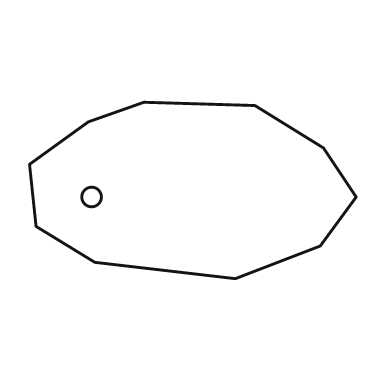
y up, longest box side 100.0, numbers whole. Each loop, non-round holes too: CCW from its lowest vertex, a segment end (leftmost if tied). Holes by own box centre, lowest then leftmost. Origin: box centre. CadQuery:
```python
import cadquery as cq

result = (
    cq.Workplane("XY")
    .moveTo(13.0, -27.0)
    .lineTo(39.0, -17.0)
    .lineTo(50.0, -2.0)
    .lineTo(40.0, 13.0)
    .lineTo(19.0, 26.0)
    .lineTo(-15.0, 27.0)
    .lineTo(-32.0, 21.0)
    .lineTo(-50.0, 8.0)
    .lineTo(-48.0, -11.0)
    .lineTo(-30.0, -22.0)
    .close()
    .moveTo(-31.0, -2.0)
    .circle(3.0)
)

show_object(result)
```